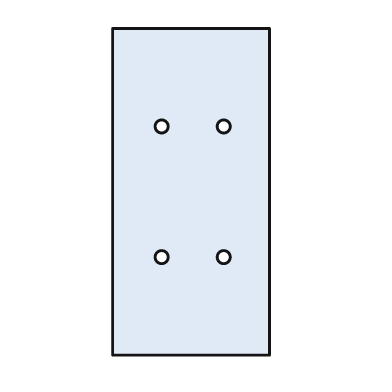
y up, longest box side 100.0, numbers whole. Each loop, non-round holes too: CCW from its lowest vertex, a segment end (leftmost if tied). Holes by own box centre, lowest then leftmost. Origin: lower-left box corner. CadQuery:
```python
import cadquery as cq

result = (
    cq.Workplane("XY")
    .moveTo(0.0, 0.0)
    .lineTo(48.0, 0.0)
    .lineTo(48.0, 100.0)
    .lineTo(0.0, 100.0)
    .close()
    .moveTo(15.0, 30.0)
    .circle(2.0)
    .moveTo(34.0, 30.0)
    .circle(2.0)
    .moveTo(15.0, 70.0)
    .circle(2.0)
    .moveTo(34.0, 70.0)
    .circle(2.0)
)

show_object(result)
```